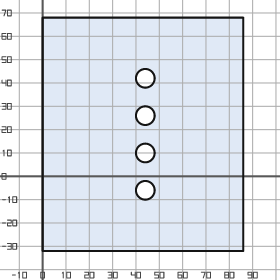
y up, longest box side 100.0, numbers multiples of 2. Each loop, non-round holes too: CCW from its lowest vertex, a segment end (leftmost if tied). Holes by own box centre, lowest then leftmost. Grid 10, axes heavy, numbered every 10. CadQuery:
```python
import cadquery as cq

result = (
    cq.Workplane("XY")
    .moveTo(0.0, -32.0)
    .lineTo(86.0, -32.0)
    .lineTo(86.0, 68.0)
    .lineTo(0.0, 68.0)
    .close()
    .moveTo(44.0, -6.0)
    .circle(4.0)
    .moveTo(44.0, 10.0)
    .circle(4.0)
    .moveTo(44.0, 26.0)
    .circle(4.0)
    .moveTo(44.0, 42.0)
    .circle(4.0)
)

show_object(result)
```